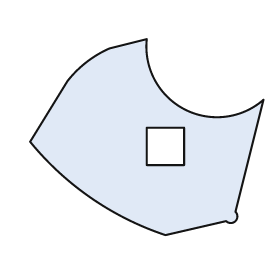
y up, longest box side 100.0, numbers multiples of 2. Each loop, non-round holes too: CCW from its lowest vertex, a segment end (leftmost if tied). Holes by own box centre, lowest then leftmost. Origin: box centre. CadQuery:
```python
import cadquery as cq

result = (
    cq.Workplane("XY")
    .moveTo(8.0, -42.0)
    .lineTo(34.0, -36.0)
    .threePointArc((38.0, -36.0), (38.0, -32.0))
    .lineTo(50.0, 16.0)
    .threePointArc((16.0, 12.0), (0.0, 42.0))
    .lineTo(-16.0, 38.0)
    .threePointArc((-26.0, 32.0), (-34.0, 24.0))
    .lineTo(-50.0, -2.0)
    .threePointArc((-24.0, -26.0), (8.0, -42.0))
    .close()
    .moveTo(0.0, -12.0)
    .lineTo(16.0, -12.0)
    .lineTo(16.0, 4.0)
    .lineTo(0.0, 4.0)
    .close()
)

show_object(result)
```